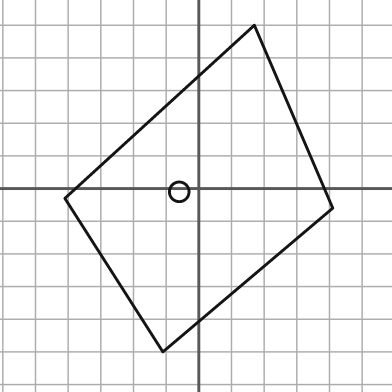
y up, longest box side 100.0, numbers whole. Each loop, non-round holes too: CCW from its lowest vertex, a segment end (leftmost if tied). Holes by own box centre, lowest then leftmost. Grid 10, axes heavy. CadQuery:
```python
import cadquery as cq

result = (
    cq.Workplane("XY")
    .moveTo(-11.0, -50.0)
    .lineTo(41.0, -6.0)
    .lineTo(17.0, 50.0)
    .lineTo(-41.0, -3.0)
    .close()
    .moveTo(-6.0, -1.0)
    .circle(3.0)
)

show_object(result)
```